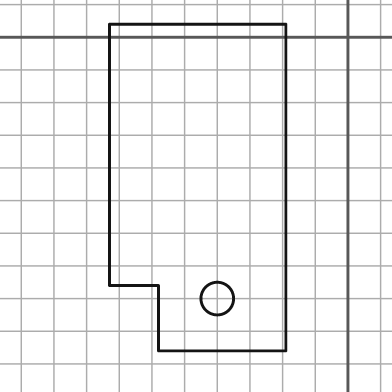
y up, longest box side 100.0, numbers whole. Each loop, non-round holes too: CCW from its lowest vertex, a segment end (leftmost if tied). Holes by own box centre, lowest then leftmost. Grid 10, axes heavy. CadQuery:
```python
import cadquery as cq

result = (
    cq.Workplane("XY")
    .moveTo(-58.0, -96.0)
    .lineTo(-19.0, -96.0)
    .lineTo(-19.0, 4.0)
    .lineTo(-73.0, 4.0)
    .lineTo(-73.0, -76.0)
    .lineTo(-58.0, -76.0)
    .close()
    .moveTo(-40.0, -80.0)
    .circle(5.0)
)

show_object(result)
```